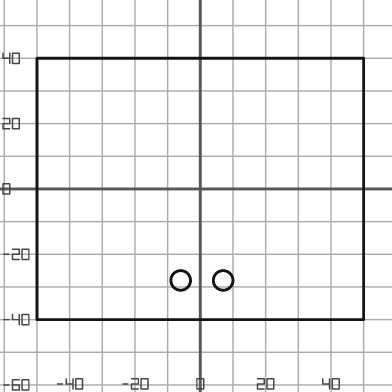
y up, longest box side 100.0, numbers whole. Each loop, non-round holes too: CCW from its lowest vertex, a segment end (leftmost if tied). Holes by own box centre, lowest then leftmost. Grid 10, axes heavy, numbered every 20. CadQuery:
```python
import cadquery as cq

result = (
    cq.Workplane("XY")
    .moveTo(-50.0, -40.0)
    .lineTo(50.0, -40.0)
    .lineTo(50.0, 40.0)
    .lineTo(-50.0, 40.0)
    .close()
    .moveTo(-6.0, -28.0)
    .circle(3.0)
    .moveTo(7.0, -28.0)
    .circle(3.0)
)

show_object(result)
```